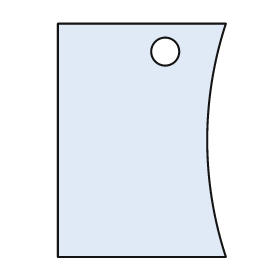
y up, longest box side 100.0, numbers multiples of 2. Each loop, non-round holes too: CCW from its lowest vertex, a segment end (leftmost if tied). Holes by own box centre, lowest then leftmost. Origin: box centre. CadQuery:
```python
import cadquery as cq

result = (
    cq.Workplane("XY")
    .moveTo(-36.0, -50.0)
    .lineTo(36.0, -50.0)
    .threePointArc((28.0, 0.0), (36.0, 50.0))
    .lineTo(-36.0, 50.0)
    .close()
    .moveTo(10.0, 38.0)
    .circle(6.0)
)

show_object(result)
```